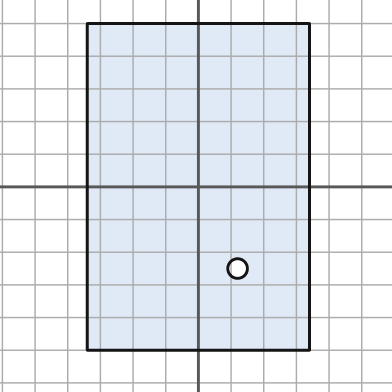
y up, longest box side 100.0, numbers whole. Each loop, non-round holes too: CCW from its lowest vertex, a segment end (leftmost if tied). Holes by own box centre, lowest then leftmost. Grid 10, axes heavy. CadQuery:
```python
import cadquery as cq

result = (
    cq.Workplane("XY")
    .moveTo(-34.0, -50.0)
    .lineTo(34.0, -50.0)
    .lineTo(34.0, 50.0)
    .lineTo(-34.0, 50.0)
    .close()
    .moveTo(12.0, -25.0)
    .circle(3.0)
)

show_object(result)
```